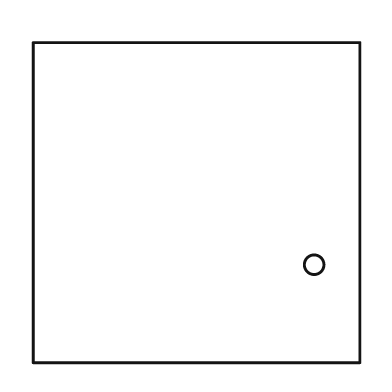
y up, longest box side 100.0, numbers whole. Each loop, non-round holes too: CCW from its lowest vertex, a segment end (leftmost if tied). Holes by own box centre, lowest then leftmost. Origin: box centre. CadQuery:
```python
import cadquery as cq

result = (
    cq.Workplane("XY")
    .moveTo(-50.0, -49.0)
    .lineTo(50.0, -49.0)
    .lineTo(50.0, 49.0)
    .lineTo(-50.0, 49.0)
    .close()
    .moveTo(36.0, -19.0)
    .circle(3.0)
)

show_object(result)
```